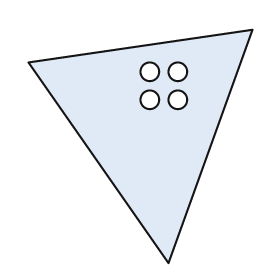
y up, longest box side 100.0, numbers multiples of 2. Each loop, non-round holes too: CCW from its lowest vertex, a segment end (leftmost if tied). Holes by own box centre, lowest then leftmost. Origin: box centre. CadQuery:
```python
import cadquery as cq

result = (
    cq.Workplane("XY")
    .moveTo(12.0, -50.0)
    .lineTo(48.0, 50.0)
    .lineTo(-48.0, 36.0)
    .close()
    .moveTo(4.0, 20.0)
    .circle(4.0)
    .moveTo(16.0, 20.0)
    .circle(4.0)
    .moveTo(4.0, 32.0)
    .circle(4.0)
    .moveTo(16.0, 32.0)
    .circle(4.0)
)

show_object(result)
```